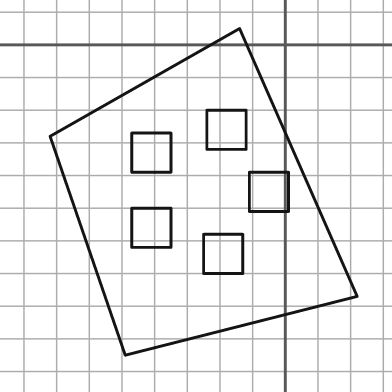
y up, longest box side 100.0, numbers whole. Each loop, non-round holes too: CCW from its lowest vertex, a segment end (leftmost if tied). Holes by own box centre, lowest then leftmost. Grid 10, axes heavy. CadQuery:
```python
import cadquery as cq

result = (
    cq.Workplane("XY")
    .moveTo(-49.0, -95.0)
    .lineTo(22.0, -77.0)
    .lineTo(-14.0, 5.0)
    .lineTo(-72.0, -28.0)
    .close()
    .moveTo(-25.0, -70.0)
    .lineTo(-13.0, -70.0)
    .lineTo(-13.0, -58.0)
    .lineTo(-25.0, -58.0)
    .close()
    .moveTo(-47.0, -62.0)
    .lineTo(-35.0, -62.0)
    .lineTo(-35.0, -50.0)
    .lineTo(-47.0, -50.0)
    .close()
    .moveTo(-11.0, -51.0)
    .lineTo(1.0, -51.0)
    .lineTo(1.0, -39.0)
    .lineTo(-11.0, -39.0)
    .close()
    .moveTo(-47.0, -39.0)
    .lineTo(-35.0, -39.0)
    .lineTo(-35.0, -27.0)
    .lineTo(-47.0, -27.0)
    .close()
    .moveTo(-24.0, -32.0)
    .lineTo(-12.0, -32.0)
    .lineTo(-12.0, -20.0)
    .lineTo(-24.0, -20.0)
    .close()
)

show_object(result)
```